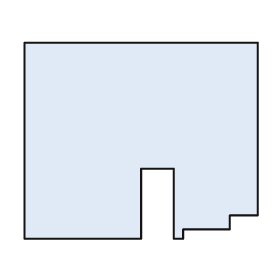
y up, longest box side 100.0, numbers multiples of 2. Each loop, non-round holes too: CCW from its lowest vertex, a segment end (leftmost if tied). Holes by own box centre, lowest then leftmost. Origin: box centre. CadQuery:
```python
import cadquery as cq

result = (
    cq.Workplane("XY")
    .moveTo(-50.0, -42.0)
    .lineTo(0.0, -42.0)
    .lineTo(0.0, -12.0)
    .lineTo(14.0, -12.0)
    .lineTo(14.0, -42.0)
    .lineTo(18.0, -42.0)
    .lineTo(18.0, -38.0)
    .lineTo(38.0, -38.0)
    .lineTo(38.0, -32.0)
    .lineTo(50.0, -32.0)
    .lineTo(50.0, 42.0)
    .lineTo(-50.0, 42.0)
    .close()
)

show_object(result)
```